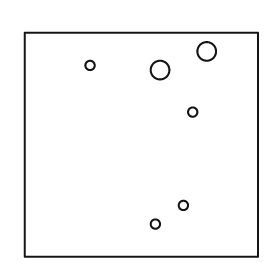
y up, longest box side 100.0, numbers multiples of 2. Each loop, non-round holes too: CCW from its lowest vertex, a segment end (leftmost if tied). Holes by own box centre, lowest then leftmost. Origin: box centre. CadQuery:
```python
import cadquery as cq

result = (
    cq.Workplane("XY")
    .moveTo(-50.0, -48.0)
    .lineTo(50.0, -48.0)
    .lineTo(50.0, 48.0)
    .lineTo(-50.0, 48.0)
    .close()
    .moveTo(6.0, -34.0)
    .circle(2.0)
    .moveTo(18.0, -26.0)
    .circle(2.0)
    .moveTo(22.0, 14.0)
    .circle(2.0)
    .moveTo(8.0, 32.0)
    .circle(4.0)
    .moveTo(-22.0, 34.0)
    .circle(2.0)
    .moveTo(28.0, 40.0)
    .circle(4.0)
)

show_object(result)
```